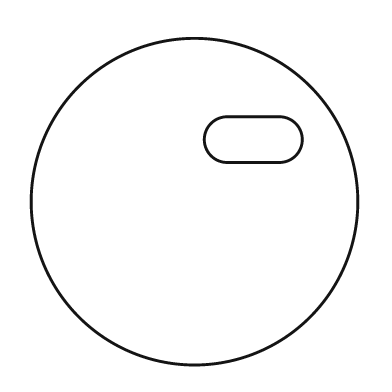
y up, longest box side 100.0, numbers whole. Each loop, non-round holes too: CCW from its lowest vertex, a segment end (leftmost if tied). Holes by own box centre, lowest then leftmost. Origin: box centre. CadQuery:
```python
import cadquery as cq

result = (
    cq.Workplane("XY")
    .moveTo(0.0, 0.0)
    .circle(50.0)
    .moveTo(10.0, 12.0)
    .lineTo(26.0, 12.0)
    .threePointArc((33.0, 19.0), (26.0, 26.0))
    .lineTo(10.0, 26.0)
    .threePointArc((3.0, 19.0), (10.0, 12.0))
    .close()
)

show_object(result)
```